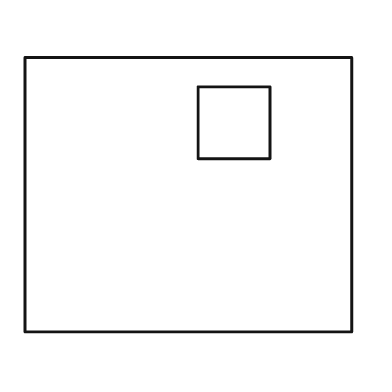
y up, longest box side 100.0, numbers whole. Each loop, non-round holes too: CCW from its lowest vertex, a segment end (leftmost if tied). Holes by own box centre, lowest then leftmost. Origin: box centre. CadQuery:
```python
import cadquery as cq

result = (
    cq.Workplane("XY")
    .moveTo(-50.0, -42.0)
    .lineTo(50.0, -42.0)
    .lineTo(50.0, 42.0)
    .lineTo(-50.0, 42.0)
    .close()
    .moveTo(3.0, 11.0)
    .lineTo(25.0, 11.0)
    .lineTo(25.0, 33.0)
    .lineTo(3.0, 33.0)
    .close()
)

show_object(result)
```